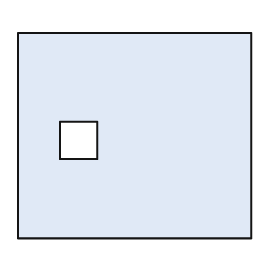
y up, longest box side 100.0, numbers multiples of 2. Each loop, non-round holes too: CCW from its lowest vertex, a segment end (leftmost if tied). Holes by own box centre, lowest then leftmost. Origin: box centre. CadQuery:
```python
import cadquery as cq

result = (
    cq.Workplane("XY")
    .moveTo(-50.0, -44.0)
    .lineTo(50.0, -44.0)
    .lineTo(50.0, 44.0)
    .lineTo(-50.0, 44.0)
    .close()
    .moveTo(-32.0, -10.0)
    .lineTo(-16.0, -10.0)
    .lineTo(-16.0, 6.0)
    .lineTo(-32.0, 6.0)
    .close()
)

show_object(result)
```